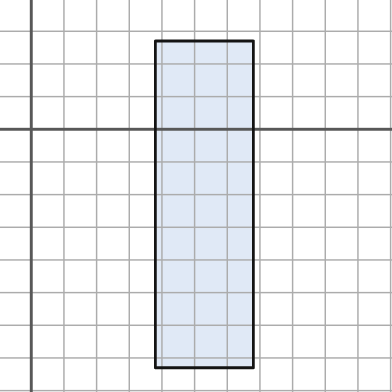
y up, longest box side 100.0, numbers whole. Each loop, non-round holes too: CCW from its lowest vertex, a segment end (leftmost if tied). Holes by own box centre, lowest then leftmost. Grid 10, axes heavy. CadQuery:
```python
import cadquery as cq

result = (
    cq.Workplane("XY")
    .moveTo(38.0, -73.0)
    .lineTo(68.0, -73.0)
    .lineTo(68.0, 27.0)
    .lineTo(38.0, 27.0)
    .close()
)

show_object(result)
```